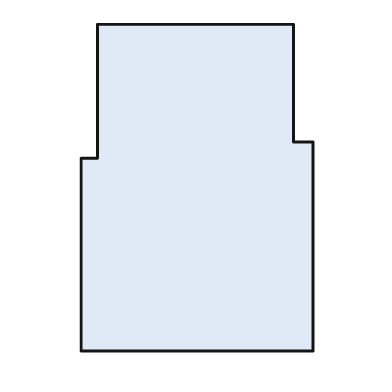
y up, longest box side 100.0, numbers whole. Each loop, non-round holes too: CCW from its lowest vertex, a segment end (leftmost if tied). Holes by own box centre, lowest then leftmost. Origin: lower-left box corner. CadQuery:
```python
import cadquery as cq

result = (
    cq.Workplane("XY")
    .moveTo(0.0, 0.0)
    .lineTo(71.0, 0.0)
    .lineTo(71.0, 64.0)
    .lineTo(65.0, 64.0)
    .lineTo(65.0, 100.0)
    .lineTo(5.0, 100.0)
    .lineTo(5.0, 59.0)
    .lineTo(0.0, 59.0)
    .close()
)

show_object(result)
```